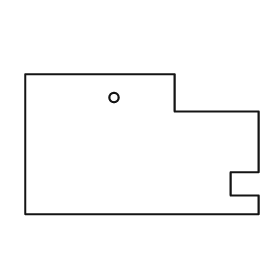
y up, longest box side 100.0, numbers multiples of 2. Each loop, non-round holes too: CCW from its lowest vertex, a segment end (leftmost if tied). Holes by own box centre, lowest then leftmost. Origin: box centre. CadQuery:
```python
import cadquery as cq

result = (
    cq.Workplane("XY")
    .moveTo(-50.0, -30.0)
    .lineTo(50.0, -30.0)
    .lineTo(50.0, -22.0)
    .lineTo(38.0, -22.0)
    .lineTo(38.0, -12.0)
    .lineTo(50.0, -12.0)
    .lineTo(50.0, 14.0)
    .lineTo(14.0, 14.0)
    .lineTo(14.0, 30.0)
    .lineTo(-50.0, 30.0)
    .close()
    .moveTo(-12.0, 20.0)
    .circle(2.0)
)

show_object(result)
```